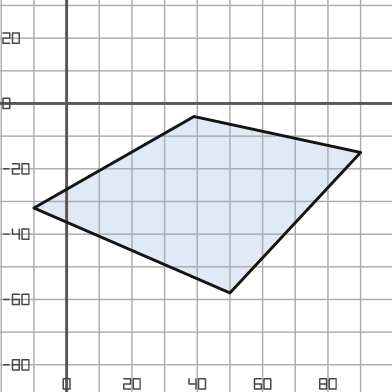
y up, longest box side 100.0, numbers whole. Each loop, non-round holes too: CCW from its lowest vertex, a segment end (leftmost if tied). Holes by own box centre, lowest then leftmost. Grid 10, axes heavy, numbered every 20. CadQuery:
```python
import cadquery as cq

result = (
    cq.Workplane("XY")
    .moveTo(50.0, -58.0)
    .lineTo(90.0, -15.0)
    .lineTo(39.0, -4.0)
    .lineTo(-10.0, -32.0)
    .close()
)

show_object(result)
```